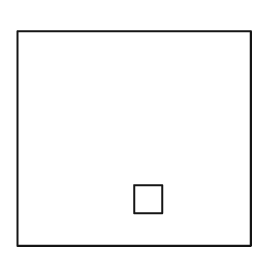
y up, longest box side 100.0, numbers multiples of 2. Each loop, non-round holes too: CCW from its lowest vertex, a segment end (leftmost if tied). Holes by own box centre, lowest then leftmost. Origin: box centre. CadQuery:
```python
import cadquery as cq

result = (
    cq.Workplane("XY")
    .moveTo(-50.0, -46.0)
    .lineTo(50.0, -46.0)
    .lineTo(50.0, 46.0)
    .lineTo(-50.0, 46.0)
    .close()
    .moveTo(0.0, -32.0)
    .lineTo(12.0, -32.0)
    .lineTo(12.0, -20.0)
    .lineTo(0.0, -20.0)
    .close()
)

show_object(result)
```